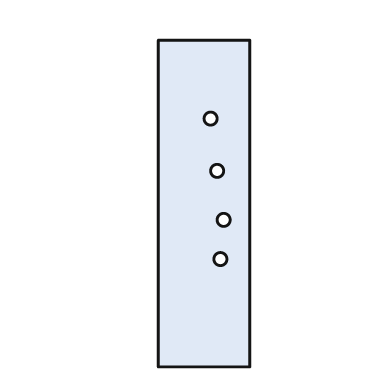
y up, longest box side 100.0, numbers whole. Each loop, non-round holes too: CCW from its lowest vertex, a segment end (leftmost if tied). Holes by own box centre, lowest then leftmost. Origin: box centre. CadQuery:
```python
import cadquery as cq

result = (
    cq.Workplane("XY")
    .moveTo(-14.0, -50.0)
    .lineTo(14.0, -50.0)
    .lineTo(14.0, 50.0)
    .lineTo(-14.0, 50.0)
    .close()
    .moveTo(5.0, -17.0)
    .circle(2.0)
    .moveTo(6.0, -5.0)
    .circle(2.0)
    .moveTo(4.0, 10.0)
    .circle(2.0)
    .moveTo(2.0, 26.0)
    .circle(2.0)
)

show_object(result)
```